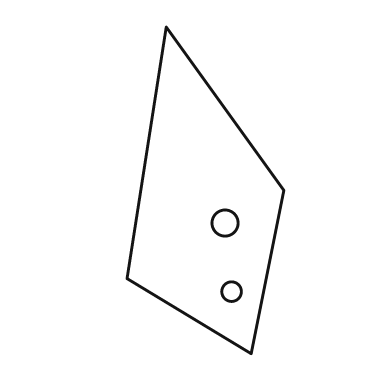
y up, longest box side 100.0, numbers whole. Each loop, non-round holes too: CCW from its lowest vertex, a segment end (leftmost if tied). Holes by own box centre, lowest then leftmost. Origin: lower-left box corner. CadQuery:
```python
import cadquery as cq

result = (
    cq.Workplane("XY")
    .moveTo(38.0, 0.0)
    .lineTo(48.0, 50.0)
    .lineTo(12.0, 100.0)
    .lineTo(0.0, 23.0)
    .close()
    .moveTo(32.0, 19.0)
    .circle(3.0)
    .moveTo(30.0, 40.0)
    .circle(4.0)
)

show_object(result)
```